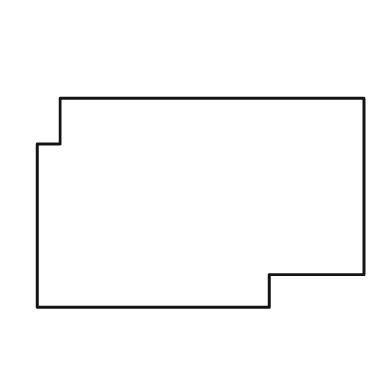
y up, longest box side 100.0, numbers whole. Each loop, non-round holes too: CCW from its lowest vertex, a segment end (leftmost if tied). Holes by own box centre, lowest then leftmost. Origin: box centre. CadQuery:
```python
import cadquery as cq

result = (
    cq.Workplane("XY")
    .moveTo(-50.0, -32.0)
    .lineTo(21.0, -32.0)
    .lineTo(21.0, -22.0)
    .lineTo(50.0, -22.0)
    .lineTo(50.0, 32.0)
    .lineTo(-43.0, 32.0)
    .lineTo(-43.0, 18.0)
    .lineTo(-50.0, 18.0)
    .close()
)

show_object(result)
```